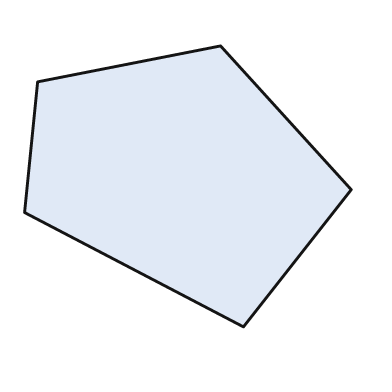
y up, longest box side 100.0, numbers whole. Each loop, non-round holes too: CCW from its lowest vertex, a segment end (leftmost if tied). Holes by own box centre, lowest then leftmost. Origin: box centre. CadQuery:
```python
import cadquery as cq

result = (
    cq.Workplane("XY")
    .moveTo(17.0, -43.0)
    .lineTo(50.0, -1.0)
    .lineTo(10.0, 43.0)
    .lineTo(-46.0, 32.0)
    .lineTo(-50.0, -8.0)
    .close()
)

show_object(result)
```